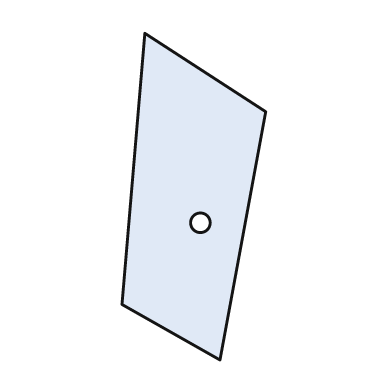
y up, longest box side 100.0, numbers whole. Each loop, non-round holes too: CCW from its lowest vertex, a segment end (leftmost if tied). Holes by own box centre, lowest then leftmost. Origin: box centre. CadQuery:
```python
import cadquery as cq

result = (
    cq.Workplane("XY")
    .moveTo(8.0, -50.0)
    .lineTo(22.0, 26.0)
    .lineTo(-15.0, 50.0)
    .lineTo(-22.0, -33.0)
    .close()
    .moveTo(2.0, -8.0)
    .circle(3.0)
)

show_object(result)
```